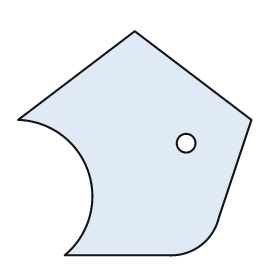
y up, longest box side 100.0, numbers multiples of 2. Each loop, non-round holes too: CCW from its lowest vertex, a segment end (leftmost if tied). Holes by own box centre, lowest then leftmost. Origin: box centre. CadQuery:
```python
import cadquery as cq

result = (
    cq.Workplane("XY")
    .moveTo(-30.0, -48.0)
    .lineTo(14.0, -48.0)
    .threePointArc((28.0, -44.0), (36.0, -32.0))
    .lineTo(50.0, 10.0)
    .lineTo(0.0, 48.0)
    .lineTo(-50.0, 10.0)
    .threePointArc((-20.0, -12.0), (-30.0, -48.0))
    .close()
    .moveTo(22.0, 0.0)
    .circle(4.0)
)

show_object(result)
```